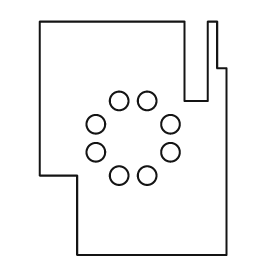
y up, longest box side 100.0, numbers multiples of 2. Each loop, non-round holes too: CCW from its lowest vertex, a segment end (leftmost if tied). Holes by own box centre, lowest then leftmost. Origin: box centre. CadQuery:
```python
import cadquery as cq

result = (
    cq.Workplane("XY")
    .moveTo(-24.0, -50.0)
    .lineTo(40.0, -50.0)
    .lineTo(40.0, 30.0)
    .lineTo(36.0, 30.0)
    .lineTo(36.0, 50.0)
    .lineTo(32.0, 50.0)
    .lineTo(32.0, 16.0)
    .lineTo(22.0, 16.0)
    .lineTo(22.0, 50.0)
    .lineTo(-40.0, 50.0)
    .lineTo(-40.0, -16.0)
    .lineTo(-24.0, -16.0)
    .close()
    .moveTo(-6.0, -16.0)
    .circle(4.0)
    .moveTo(6.0, -16.0)
    .circle(4.0)
    .moveTo(-16.0, -6.0)
    .circle(4.0)
    .moveTo(16.0, -6.0)
    .circle(4.0)
    .moveTo(-16.0, 6.0)
    .circle(4.0)
    .moveTo(16.0, 6.0)
    .circle(4.0)
    .moveTo(-6.0, 16.0)
    .circle(4.0)
    .moveTo(6.0, 16.0)
    .circle(4.0)
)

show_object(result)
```